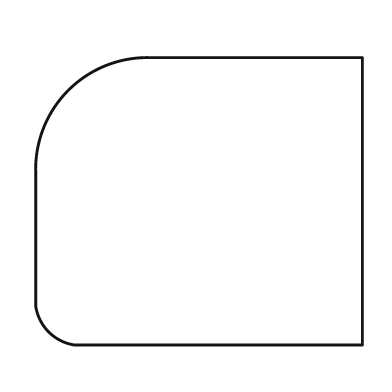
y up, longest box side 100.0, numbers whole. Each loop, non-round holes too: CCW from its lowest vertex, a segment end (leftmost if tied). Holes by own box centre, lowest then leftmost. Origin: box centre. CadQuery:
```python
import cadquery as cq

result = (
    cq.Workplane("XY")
    .moveTo(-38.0, -44.0)
    .lineTo(50.0, -44.0)
    .lineTo(50.0, 44.0)
    .lineTo(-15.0, 44.0)
    .threePointArc((-40.0, 34.0), (-50.0, 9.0))
    .lineTo(-50.0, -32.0)
    .threePointArc((-46.0, -40.0), (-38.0, -44.0))
    .close()
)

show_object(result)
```